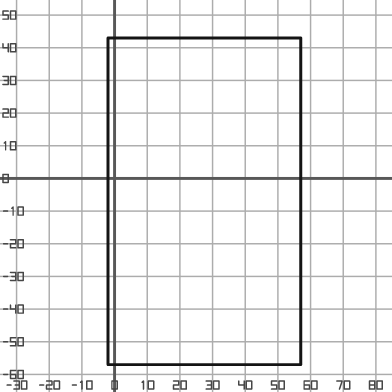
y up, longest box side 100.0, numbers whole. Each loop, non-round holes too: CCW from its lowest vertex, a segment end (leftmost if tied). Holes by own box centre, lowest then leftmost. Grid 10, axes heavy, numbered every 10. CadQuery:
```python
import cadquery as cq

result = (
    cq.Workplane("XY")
    .moveTo(-2.0, -57.0)
    .lineTo(57.0, -57.0)
    .lineTo(57.0, 43.0)
    .lineTo(-2.0, 43.0)
    .close()
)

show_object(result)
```